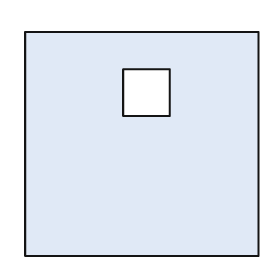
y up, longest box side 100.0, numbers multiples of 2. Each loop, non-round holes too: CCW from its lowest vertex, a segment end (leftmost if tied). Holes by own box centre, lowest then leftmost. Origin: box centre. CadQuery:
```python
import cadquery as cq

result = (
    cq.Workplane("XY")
    .moveTo(-50.0, -48.0)
    .lineTo(50.0, -48.0)
    .lineTo(50.0, 48.0)
    .lineTo(-50.0, 48.0)
    .close()
    .moveTo(-8.0, 12.0)
    .lineTo(12.0, 12.0)
    .lineTo(12.0, 32.0)
    .lineTo(-8.0, 32.0)
    .close()
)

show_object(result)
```